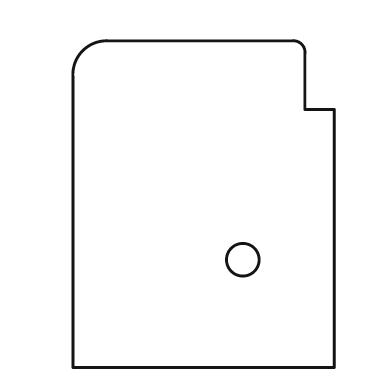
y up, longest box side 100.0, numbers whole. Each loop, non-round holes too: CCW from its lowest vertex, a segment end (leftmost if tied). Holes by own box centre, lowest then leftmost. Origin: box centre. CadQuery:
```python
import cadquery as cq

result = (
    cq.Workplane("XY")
    .moveTo(-40.0, -50.0)
    .lineTo(40.0, -50.0)
    .lineTo(40.0, 29.0)
    .lineTo(31.0, 29.0)
    .lineTo(31.0, 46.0)
    .threePointArc((30.0, 49.0), (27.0, 50.0))
    .lineTo(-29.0, 50.0)
    .threePointArc((-37.0, 47.0), (-40.0, 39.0))
    .close()
    .moveTo(12.0, -17.0)
    .circle(5.0)
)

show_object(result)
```